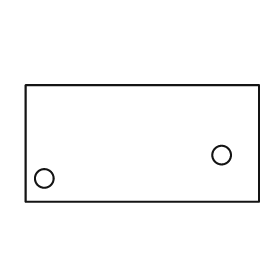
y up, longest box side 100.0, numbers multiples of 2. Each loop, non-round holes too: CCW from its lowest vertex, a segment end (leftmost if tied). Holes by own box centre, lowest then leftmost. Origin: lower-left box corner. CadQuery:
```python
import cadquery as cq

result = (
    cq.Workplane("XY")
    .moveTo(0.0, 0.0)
    .lineTo(100.0, 0.0)
    .lineTo(100.0, 50.0)
    .lineTo(0.0, 50.0)
    .close()
    .moveTo(8.0, 10.0)
    .circle(4.0)
    .moveTo(84.0, 20.0)
    .circle(4.0)
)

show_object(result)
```